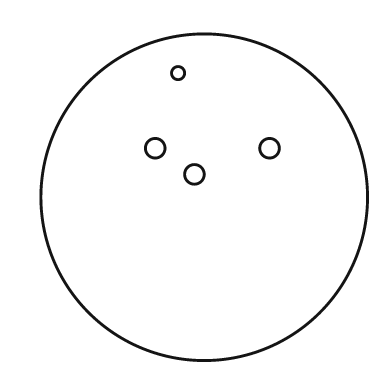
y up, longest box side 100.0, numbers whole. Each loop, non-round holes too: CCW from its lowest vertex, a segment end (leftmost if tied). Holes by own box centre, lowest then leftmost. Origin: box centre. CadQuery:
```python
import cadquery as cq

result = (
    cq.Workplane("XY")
    .moveTo(0.0, 0.0)
    .circle(50.0)
    .moveTo(-3.0, 7.0)
    .circle(3.0)
    .moveTo(-15.0, 15.0)
    .circle(3.0)
    .moveTo(20.0, 15.0)
    .circle(3.0)
    .moveTo(-8.0, 38.0)
    .circle(2.0)
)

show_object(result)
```